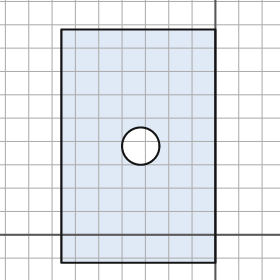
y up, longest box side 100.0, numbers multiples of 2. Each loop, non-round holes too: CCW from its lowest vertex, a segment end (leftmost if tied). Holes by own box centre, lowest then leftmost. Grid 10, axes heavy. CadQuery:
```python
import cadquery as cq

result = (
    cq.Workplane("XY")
    .moveTo(-66.0, -12.0)
    .lineTo(0.0, -12.0)
    .lineTo(0.0, 88.0)
    .lineTo(-66.0, 88.0)
    .close()
    .moveTo(-32.0, 38.0)
    .circle(8.0)
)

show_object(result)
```